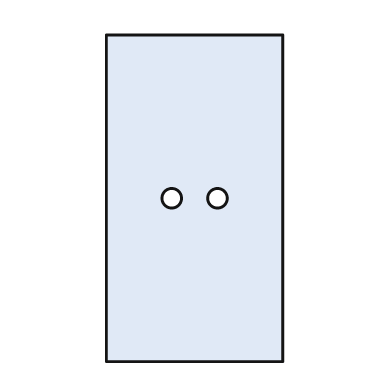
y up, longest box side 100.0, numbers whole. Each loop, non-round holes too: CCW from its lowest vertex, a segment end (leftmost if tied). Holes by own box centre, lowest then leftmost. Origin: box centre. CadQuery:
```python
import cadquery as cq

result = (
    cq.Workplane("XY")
    .moveTo(-27.0, -50.0)
    .lineTo(27.0, -50.0)
    .lineTo(27.0, 50.0)
    .lineTo(-27.0, 50.0)
    .close()
    .moveTo(-7.0, 0.0)
    .circle(3.0)
    .moveTo(7.0, 0.0)
    .circle(3.0)
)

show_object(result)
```